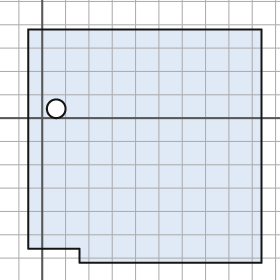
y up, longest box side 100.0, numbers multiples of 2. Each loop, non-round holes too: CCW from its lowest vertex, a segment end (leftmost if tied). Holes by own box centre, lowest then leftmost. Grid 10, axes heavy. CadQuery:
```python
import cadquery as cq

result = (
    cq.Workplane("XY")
    .moveTo(16.0, -62.0)
    .lineTo(94.0, -62.0)
    .lineTo(94.0, 38.0)
    .lineTo(-6.0, 38.0)
    .lineTo(-6.0, -56.0)
    .lineTo(16.0, -56.0)
    .close()
    .moveTo(6.0, 4.0)
    .circle(4.0)
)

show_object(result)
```